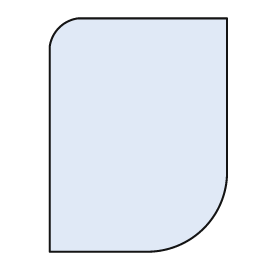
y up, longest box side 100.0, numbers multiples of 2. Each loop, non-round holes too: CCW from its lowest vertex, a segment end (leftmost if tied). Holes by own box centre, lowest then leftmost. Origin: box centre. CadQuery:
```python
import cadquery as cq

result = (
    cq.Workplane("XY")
    .moveTo(-38.0, -50.0)
    .lineTo(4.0, -50.0)
    .threePointArc((28.0, -40.0), (38.0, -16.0))
    .lineTo(38.0, 50.0)
    .lineTo(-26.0, 50.0)
    .threePointArc((-34.0, 46.0), (-38.0, 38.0))
    .close()
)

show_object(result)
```